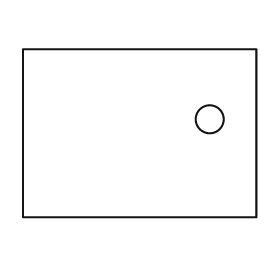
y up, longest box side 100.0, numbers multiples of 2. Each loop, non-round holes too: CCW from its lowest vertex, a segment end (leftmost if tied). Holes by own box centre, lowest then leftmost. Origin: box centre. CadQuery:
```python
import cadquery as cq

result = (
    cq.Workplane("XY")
    .moveTo(-50.0, -36.0)
    .lineTo(50.0, -36.0)
    .lineTo(50.0, 36.0)
    .lineTo(-50.0, 36.0)
    .close()
    .moveTo(30.0, 6.0)
    .circle(6.0)
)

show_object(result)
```